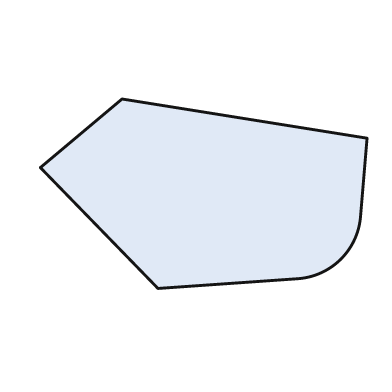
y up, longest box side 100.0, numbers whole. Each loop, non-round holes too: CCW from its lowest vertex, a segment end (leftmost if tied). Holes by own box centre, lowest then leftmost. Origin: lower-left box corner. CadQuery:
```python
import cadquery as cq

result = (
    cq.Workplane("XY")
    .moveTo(36.0, 0.0)
    .lineTo(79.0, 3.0)
    .threePointArc((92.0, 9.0), (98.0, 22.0))
    .lineTo(100.0, 46.0)
    .lineTo(25.0, 58.0)
    .lineTo(0.0, 37.0)
    .close()
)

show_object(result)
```